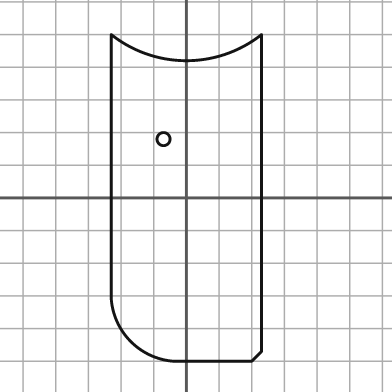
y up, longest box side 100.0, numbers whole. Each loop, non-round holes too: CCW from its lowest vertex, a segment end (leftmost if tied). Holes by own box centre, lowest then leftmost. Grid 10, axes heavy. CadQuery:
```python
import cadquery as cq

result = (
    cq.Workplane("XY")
    .moveTo(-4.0, -50.0)
    .lineTo(20.0, -50.0)
    .lineTo(23.0, -47.0)
    .lineTo(23.0, 50.0)
    .threePointArc((0.0, 42.0), (-23.0, 50.0))
    .lineTo(-23.0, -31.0)
    .threePointArc((-17.0, -44.0), (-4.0, -50.0))
    .close()
    .moveTo(-7.0, 18.0)
    .circle(2.0)
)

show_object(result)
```